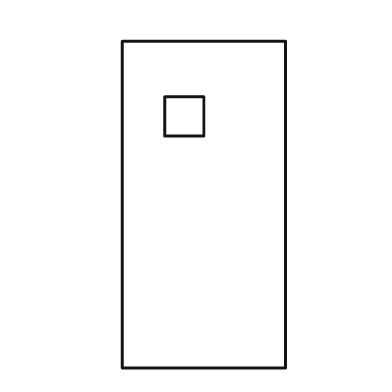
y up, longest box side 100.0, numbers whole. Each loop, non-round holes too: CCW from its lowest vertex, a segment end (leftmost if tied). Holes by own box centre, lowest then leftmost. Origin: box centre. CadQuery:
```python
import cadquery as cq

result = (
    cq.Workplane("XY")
    .moveTo(-25.0, -50.0)
    .lineTo(25.0, -50.0)
    .lineTo(25.0, 50.0)
    .lineTo(-25.0, 50.0)
    .close()
    .moveTo(-12.0, 21.0)
    .lineTo(0.0, 21.0)
    .lineTo(0.0, 33.0)
    .lineTo(-12.0, 33.0)
    .close()
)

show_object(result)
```